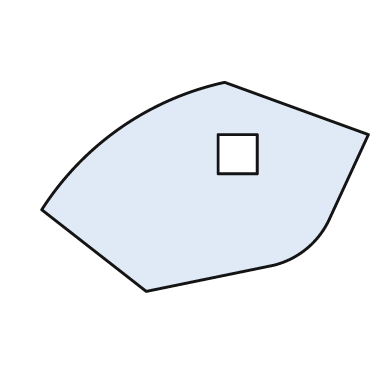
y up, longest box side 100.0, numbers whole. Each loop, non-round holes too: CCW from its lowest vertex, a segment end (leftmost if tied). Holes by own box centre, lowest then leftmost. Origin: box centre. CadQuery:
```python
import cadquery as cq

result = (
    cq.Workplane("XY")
    .moveTo(-18.0, -32.0)
    .lineTo(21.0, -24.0)
    .threePointArc((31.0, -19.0), (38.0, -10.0))
    .lineTo(50.0, 16.0)
    .lineTo(6.0, 32.0)
    .threePointArc((-26.0, 18.0), (-50.0, -7.0))
    .close()
    .moveTo(4.0, 4.0)
    .lineTo(16.0, 4.0)
    .lineTo(16.0, 16.0)
    .lineTo(4.0, 16.0)
    .close()
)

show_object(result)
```